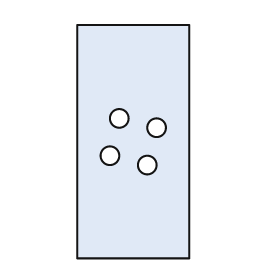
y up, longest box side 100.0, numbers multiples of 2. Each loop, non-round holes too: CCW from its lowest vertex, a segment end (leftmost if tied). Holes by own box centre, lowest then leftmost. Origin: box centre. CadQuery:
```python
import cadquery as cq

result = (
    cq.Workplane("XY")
    .moveTo(-24.0, -50.0)
    .lineTo(24.0, -50.0)
    .lineTo(24.0, 50.0)
    .lineTo(-24.0, 50.0)
    .close()
    .moveTo(6.0, -10.0)
    .circle(4.0)
    .moveTo(-10.0, -6.0)
    .circle(4.0)
    .moveTo(10.0, 6.0)
    .circle(4.0)
    .moveTo(-6.0, 10.0)
    .circle(4.0)
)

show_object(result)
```